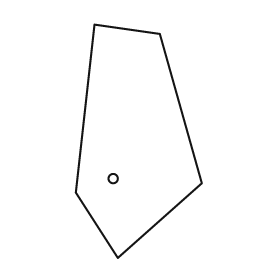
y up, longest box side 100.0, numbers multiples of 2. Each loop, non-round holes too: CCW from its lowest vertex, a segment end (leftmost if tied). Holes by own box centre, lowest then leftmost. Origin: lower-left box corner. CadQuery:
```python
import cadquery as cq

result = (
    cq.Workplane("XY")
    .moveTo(18.0, 0.0)
    .lineTo(54.0, 32.0)
    .lineTo(36.0, 96.0)
    .lineTo(8.0, 100.0)
    .lineTo(0.0, 28.0)
    .close()
    .moveTo(16.0, 34.0)
    .circle(2.0)
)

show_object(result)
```